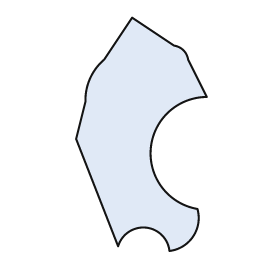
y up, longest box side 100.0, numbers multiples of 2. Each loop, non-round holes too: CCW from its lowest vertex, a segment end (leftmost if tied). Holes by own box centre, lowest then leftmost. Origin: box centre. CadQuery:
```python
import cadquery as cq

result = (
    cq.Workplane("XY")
    .moveTo(12.0, -50.0)
    .threePointArc((22.0, -44.0), (24.0, -32.0))
    .threePointArc((4.0, -6.0), (28.0, 16.0))
    .lineTo(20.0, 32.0)
    .threePointArc((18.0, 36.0), (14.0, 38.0))
    .lineTo(-4.0, 50.0)
    .lineTo(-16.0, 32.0)
    .threePointArc((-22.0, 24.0), (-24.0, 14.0))
    .lineTo(-28.0, -2.0)
    .lineTo(-10.0, -48.0)
    .threePointArc((2.0, -40.0), (12.0, -50.0))
    .close()
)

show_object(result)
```